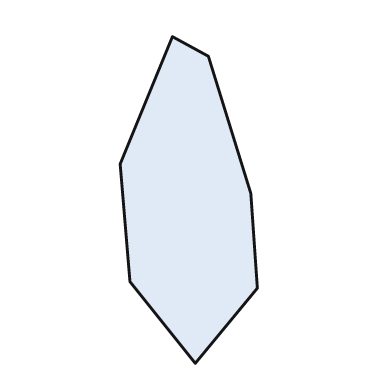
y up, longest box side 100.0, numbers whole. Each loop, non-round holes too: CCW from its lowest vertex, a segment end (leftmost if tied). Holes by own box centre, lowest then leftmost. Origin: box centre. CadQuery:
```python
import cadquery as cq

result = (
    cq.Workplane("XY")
    .moveTo(2.0, -50.0)
    .lineTo(21.0, -27.0)
    .lineTo(19.0, 2.0)
    .lineTo(6.0, 44.0)
    .lineTo(-5.0, 50.0)
    .lineTo(-21.0, 11.0)
    .lineTo(-18.0, -25.0)
    .close()
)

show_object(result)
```